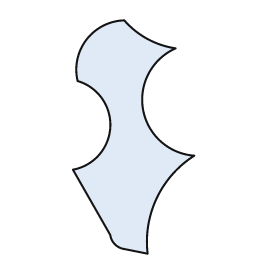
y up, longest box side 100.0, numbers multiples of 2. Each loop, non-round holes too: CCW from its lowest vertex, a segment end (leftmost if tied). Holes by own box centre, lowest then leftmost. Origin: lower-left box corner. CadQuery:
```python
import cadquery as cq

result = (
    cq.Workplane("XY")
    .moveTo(32.0, 0.0)
    .threePointArc((36.0, 24.0), (52.0, 42.0))
    .threePointArc((30.0, 62.0), (44.0, 88.0))
    .threePointArc((32.0, 92.0), (22.0, 100.0))
    .threePointArc((6.0, 92.0), (2.0, 74.0))
    .threePointArc((16.0, 54.0), (0.0, 36.0))
    .lineTo(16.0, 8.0)
    .threePointArc((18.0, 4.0), (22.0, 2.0))
    .close()
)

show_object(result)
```